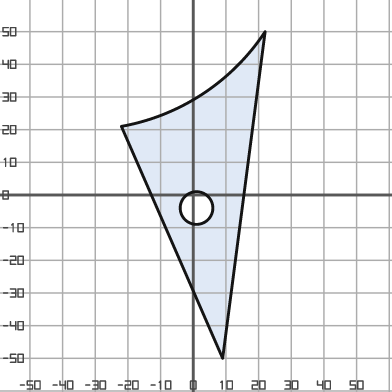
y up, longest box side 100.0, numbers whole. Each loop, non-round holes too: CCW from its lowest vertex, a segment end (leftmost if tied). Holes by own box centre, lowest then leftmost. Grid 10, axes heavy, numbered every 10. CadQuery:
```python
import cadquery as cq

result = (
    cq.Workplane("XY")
    .moveTo(9.0, -50.0)
    .lineTo(22.0, 50.0)
    .threePointArc((3.0, 31.0), (-22.0, 21.0))
    .close()
    .moveTo(1.0, -4.0)
    .circle(5.0)
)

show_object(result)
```